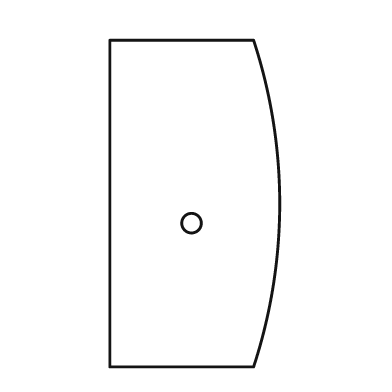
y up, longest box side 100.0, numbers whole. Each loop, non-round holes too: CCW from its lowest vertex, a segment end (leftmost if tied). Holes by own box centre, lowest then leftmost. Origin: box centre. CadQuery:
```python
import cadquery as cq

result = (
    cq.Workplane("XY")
    .moveTo(-26.0, -50.0)
    .lineTo(18.0, -50.0)
    .threePointArc((26.0, 0.0), (18.0, 50.0))
    .lineTo(-26.0, 50.0)
    .close()
    .moveTo(-1.0, -6.0)
    .circle(3.0)
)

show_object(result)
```